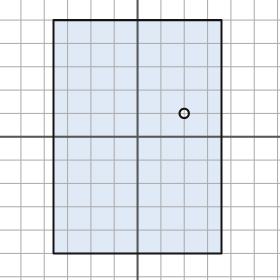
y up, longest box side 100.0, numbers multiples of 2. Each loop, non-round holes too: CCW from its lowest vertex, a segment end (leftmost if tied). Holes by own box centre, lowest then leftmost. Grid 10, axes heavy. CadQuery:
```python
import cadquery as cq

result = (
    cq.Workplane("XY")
    .moveTo(-36.0, -50.0)
    .lineTo(36.0, -50.0)
    .lineTo(36.0, 50.0)
    .lineTo(-36.0, 50.0)
    .close()
    .moveTo(20.0, 10.0)
    .circle(2.0)
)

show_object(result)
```